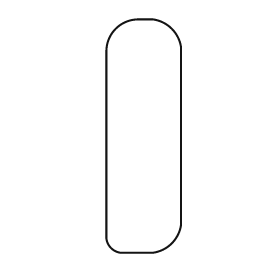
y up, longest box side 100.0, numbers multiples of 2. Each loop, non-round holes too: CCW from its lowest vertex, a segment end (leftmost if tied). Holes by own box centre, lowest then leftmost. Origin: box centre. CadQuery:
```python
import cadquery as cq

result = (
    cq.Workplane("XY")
    .moveTo(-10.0, -50.0)
    .lineTo(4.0, -50.0)
    .threePointArc((12.0, -46.0), (16.0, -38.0))
    .lineTo(16.0, 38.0)
    .threePointArc((12.0, 46.0), (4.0, 50.0))
    .lineTo(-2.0, 50.0)
    .threePointArc((-12.0, 46.0), (-16.0, 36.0))
    .lineTo(-16.0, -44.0)
    .threePointArc((-14.0, -48.0), (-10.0, -50.0))
    .close()
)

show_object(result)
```